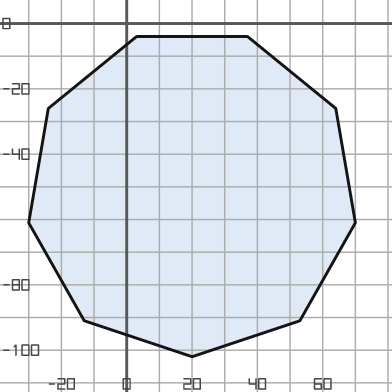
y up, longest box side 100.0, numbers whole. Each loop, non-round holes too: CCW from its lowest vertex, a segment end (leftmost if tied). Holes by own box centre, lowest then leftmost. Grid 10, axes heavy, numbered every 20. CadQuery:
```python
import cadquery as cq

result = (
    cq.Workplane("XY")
    .moveTo(20.0, -102.0)
    .lineTo(53.0, -91.0)
    .lineTo(70.0, -61.0)
    .lineTo(64.0, -26.0)
    .lineTo(37.0, -4.0)
    .lineTo(3.0, -4.0)
    .lineTo(-24.0, -26.0)
    .lineTo(-30.0, -61.0)
    .lineTo(-13.0, -91.0)
    .close()
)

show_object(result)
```